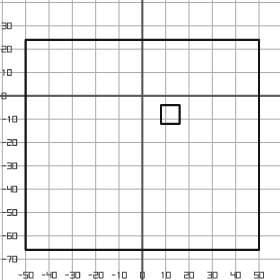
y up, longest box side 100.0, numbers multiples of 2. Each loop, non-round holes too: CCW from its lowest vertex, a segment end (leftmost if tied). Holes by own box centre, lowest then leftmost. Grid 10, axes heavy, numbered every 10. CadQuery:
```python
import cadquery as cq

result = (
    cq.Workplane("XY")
    .moveTo(-50.0, -66.0)
    .lineTo(50.0, -66.0)
    .lineTo(50.0, 24.0)
    .lineTo(-50.0, 24.0)
    .close()
    .moveTo(8.0, -12.0)
    .lineTo(16.0, -12.0)
    .lineTo(16.0, -4.0)
    .lineTo(8.0, -4.0)
    .close()
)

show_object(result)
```